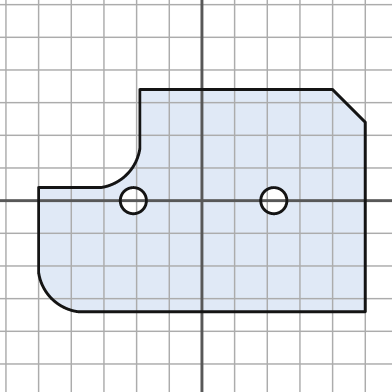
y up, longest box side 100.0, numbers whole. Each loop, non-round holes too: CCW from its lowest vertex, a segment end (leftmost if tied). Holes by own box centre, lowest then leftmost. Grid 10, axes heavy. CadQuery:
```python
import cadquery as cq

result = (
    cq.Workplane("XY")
    .moveTo(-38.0, -34.0)
    .lineTo(50.0, -34.0)
    .lineTo(50.0, 24.0)
    .lineTo(40.0, 34.0)
    .lineTo(-19.0, 34.0)
    .lineTo(-19.0, 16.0)
    .threePointArc((-23.0, 8.0), (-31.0, 4.0))
    .lineTo(-50.0, 4.0)
    .lineTo(-50.0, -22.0)
    .threePointArc((-46.0, -30.0), (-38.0, -34.0))
    .close()
    .moveTo(-21.0, 0.0)
    .circle(4.0)
    .moveTo(22.0, 0.0)
    .circle(4.0)
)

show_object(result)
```